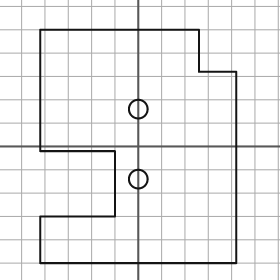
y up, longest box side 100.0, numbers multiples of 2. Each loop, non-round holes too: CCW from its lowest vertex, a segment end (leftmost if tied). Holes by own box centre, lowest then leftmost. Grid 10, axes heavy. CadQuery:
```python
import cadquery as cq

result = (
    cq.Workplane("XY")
    .moveTo(-42.0, -50.0)
    .lineTo(42.0, -50.0)
    .lineTo(42.0, 32.0)
    .lineTo(26.0, 32.0)
    .lineTo(26.0, 50.0)
    .lineTo(-42.0, 50.0)
    .lineTo(-42.0, -2.0)
    .lineTo(-10.0, -2.0)
    .lineTo(-10.0, -30.0)
    .lineTo(-42.0, -30.0)
    .close()
    .moveTo(0.0, -14.0)
    .circle(4.0)
    .moveTo(0.0, 16.0)
    .circle(4.0)
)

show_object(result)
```